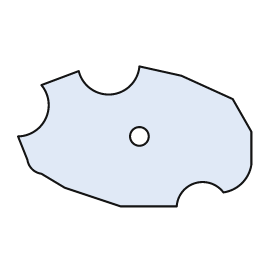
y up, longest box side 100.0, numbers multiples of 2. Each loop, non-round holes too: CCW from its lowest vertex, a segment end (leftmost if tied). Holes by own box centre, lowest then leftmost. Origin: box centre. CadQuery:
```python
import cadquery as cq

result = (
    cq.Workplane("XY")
    .moveTo(-6.0, -30.0)
    .lineTo(18.0, -30.0)
    .threePointArc((26.0, -20.0), (38.0, -24.0))
    .threePointArc((46.0, -20.0), (50.0, -12.0))
    .lineTo(50.0, 2.0)
    .lineTo(42.0, 16.0)
    .lineTo(20.0, 26.0)
    .lineTo(2.0, 30.0)
    .threePointArc((-10.0, 18.0), (-24.0, 28.0))
    .lineTo(-40.0, 22.0)
    .threePointArc((-38.0, 8.0), (-50.0, 0.0))
    .lineTo(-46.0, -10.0)
    .threePointArc((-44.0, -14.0), (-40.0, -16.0))
    .lineTo(-30.0, -22.0)
    .close()
    .moveTo(2.0, 0.0)
    .circle(4.0)
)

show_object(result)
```